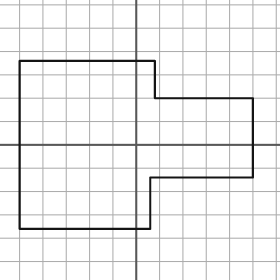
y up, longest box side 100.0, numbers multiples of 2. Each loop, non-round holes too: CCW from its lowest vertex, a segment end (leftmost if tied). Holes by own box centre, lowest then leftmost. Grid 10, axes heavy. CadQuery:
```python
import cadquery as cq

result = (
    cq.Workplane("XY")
    .moveTo(-50.0, -36.0)
    .lineTo(6.0, -36.0)
    .lineTo(6.0, -14.0)
    .lineTo(50.0, -14.0)
    .lineTo(50.0, 20.0)
    .lineTo(8.0, 20.0)
    .lineTo(8.0, 36.0)
    .lineTo(-50.0, 36.0)
    .close()
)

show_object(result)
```